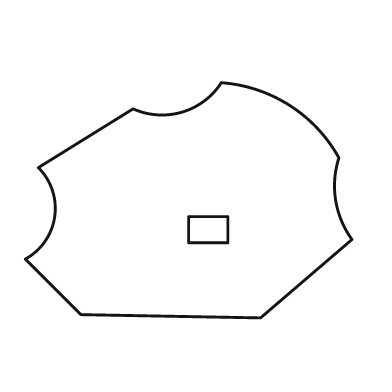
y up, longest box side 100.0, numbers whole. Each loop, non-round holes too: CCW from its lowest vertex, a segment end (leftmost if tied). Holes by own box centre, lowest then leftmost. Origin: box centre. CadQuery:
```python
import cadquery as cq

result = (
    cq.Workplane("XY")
    .moveTo(22.0, -36.0)
    .lineTo(50.0, -12.0)
    .threePointArc((45.0, 0.0), (46.0, 13.0))
    .threePointArc((31.0, 29.0), (10.0, 36.0))
    .threePointArc((-2.0, 27.0), (-17.0, 28.0))
    .lineTo(-46.0, 10.0)
    .threePointArc((-41.0, -5.0), (-50.0, -18.0))
    .lineTo(-33.0, -35.0)
    .close()
    .moveTo(0.0, -13.0)
    .lineTo(12.0, -13.0)
    .lineTo(12.0, -5.0)
    .lineTo(0.0, -5.0)
    .close()
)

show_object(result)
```